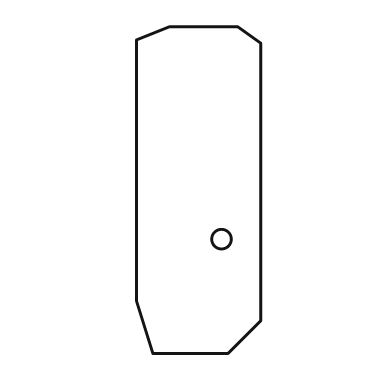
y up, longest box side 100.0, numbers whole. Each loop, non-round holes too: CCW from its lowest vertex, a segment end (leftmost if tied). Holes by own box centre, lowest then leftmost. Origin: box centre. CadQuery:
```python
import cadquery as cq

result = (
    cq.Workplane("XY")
    .moveTo(-14.0, -50.0)
    .lineTo(9.0, -50.0)
    .lineTo(19.0, -40.0)
    .lineTo(19.0, 45.0)
    .lineTo(12.0, 50.0)
    .lineTo(-9.0, 50.0)
    .lineTo(-19.0, 46.0)
    .lineTo(-19.0, -34.0)
    .close()
    .moveTo(7.0, -15.0)
    .circle(3.0)
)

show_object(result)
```